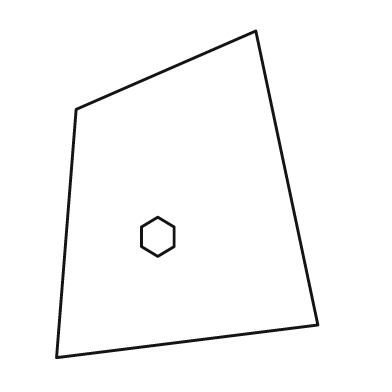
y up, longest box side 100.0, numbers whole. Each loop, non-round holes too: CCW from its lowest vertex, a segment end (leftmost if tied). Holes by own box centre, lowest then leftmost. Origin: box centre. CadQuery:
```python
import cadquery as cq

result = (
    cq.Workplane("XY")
    .moveTo(-40.0, -50.0)
    .lineTo(40.0, -40.0)
    .lineTo(21.0, 50.0)
    .lineTo(-34.0, 26.0)
    .close()
    .moveTo(-9.0, -19.0)
    .lineTo(-4.0, -16.0)
    .lineTo(-4.0, -10.0)
    .lineTo(-9.0, -7.0)
    .lineTo(-14.0, -10.0)
    .lineTo(-14.0, -16.0)
    .close()
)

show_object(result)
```